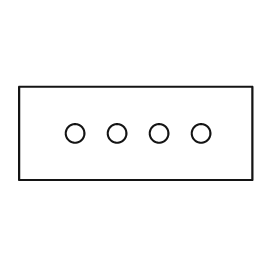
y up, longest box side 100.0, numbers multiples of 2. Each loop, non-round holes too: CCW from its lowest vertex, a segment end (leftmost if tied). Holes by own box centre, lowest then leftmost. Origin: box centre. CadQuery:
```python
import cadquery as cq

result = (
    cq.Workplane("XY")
    .moveTo(-50.0, -20.0)
    .lineTo(50.0, -20.0)
    .lineTo(50.0, 20.0)
    .lineTo(-50.0, 20.0)
    .close()
    .moveTo(-26.0, 0.0)
    .circle(4.0)
    .moveTo(-8.0, 0.0)
    .circle(4.0)
    .moveTo(10.0, 0.0)
    .circle(4.0)
    .moveTo(28.0, 0.0)
    .circle(4.0)
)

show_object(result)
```